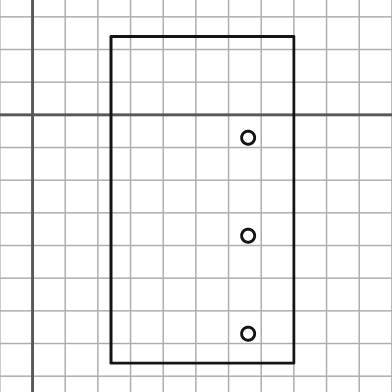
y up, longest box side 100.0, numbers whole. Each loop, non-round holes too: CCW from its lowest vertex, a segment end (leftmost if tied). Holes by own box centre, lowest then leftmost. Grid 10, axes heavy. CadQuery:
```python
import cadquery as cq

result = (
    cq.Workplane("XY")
    .moveTo(24.0, -76.0)
    .lineTo(80.0, -76.0)
    .lineTo(80.0, 24.0)
    .lineTo(24.0, 24.0)
    .close()
    .moveTo(66.0, -67.0)
    .circle(2.0)
    .moveTo(66.0, -37.0)
    .circle(2.0)
    .moveTo(66.0, -7.0)
    .circle(2.0)
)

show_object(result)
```